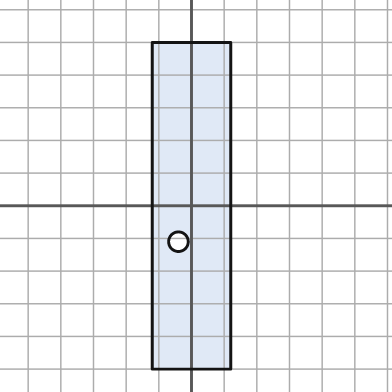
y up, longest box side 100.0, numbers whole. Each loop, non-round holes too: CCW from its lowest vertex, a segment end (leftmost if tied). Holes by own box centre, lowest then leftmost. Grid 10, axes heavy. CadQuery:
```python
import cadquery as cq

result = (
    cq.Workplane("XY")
    .moveTo(-12.0, -50.0)
    .lineTo(12.0, -50.0)
    .lineTo(12.0, 50.0)
    .lineTo(-12.0, 50.0)
    .close()
    .moveTo(-4.0, -11.0)
    .circle(3.0)
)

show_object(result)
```